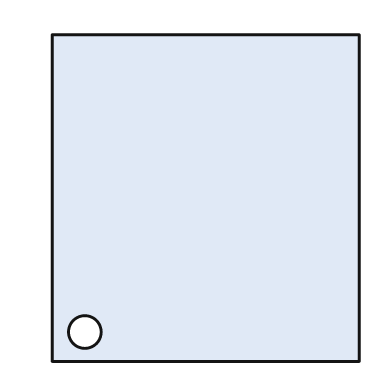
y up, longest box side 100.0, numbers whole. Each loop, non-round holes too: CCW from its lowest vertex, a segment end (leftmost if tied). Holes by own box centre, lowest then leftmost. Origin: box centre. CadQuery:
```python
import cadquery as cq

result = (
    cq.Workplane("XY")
    .moveTo(-47.0, -50.0)
    .lineTo(47.0, -50.0)
    .lineTo(47.0, 50.0)
    .lineTo(-47.0, 50.0)
    .close()
    .moveTo(-37.0, -41.0)
    .circle(5.0)
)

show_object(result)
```